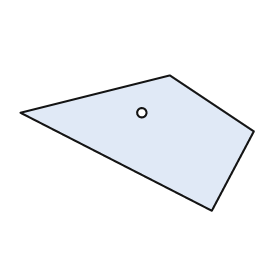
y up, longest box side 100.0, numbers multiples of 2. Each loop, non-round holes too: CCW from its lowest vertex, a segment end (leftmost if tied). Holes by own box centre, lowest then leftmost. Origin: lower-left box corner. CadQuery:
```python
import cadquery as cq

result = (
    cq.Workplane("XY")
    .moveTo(82.0, 0.0)
    .lineTo(100.0, 34.0)
    .lineTo(64.0, 58.0)
    .lineTo(0.0, 42.0)
    .close()
    .moveTo(52.0, 42.0)
    .circle(2.0)
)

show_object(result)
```